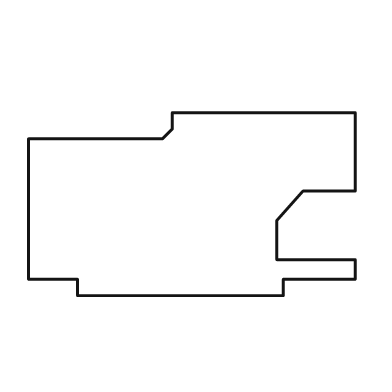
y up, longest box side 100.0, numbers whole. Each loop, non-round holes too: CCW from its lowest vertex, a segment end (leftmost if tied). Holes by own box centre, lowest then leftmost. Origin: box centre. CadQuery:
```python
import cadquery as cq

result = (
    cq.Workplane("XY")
    .moveTo(-35.0, -28.0)
    .lineTo(28.0, -28.0)
    .lineTo(28.0, -23.0)
    .lineTo(50.0, -23.0)
    .lineTo(50.0, -17.0)
    .lineTo(26.0, -17.0)
    .lineTo(26.0, -5.0)
    .lineTo(34.0, 4.0)
    .lineTo(50.0, 4.0)
    .lineTo(50.0, 28.0)
    .lineTo(-6.0, 28.0)
    .lineTo(-6.0, 23.0)
    .lineTo(-9.0, 20.0)
    .lineTo(-50.0, 20.0)
    .lineTo(-50.0, -23.0)
    .lineTo(-35.0, -23.0)
    .close()
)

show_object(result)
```